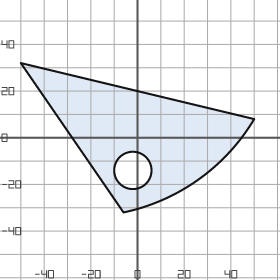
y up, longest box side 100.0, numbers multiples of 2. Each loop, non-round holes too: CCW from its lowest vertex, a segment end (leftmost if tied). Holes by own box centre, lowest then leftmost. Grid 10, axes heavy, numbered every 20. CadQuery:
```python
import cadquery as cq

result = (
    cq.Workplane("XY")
    .moveTo(-6.0, -32.0)
    .threePointArc((26.0, -18.0), (50.0, 8.0))
    .lineTo(-50.0, 32.0)
    .close()
    .moveTo(-2.0, -14.0)
    .circle(8.0)
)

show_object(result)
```